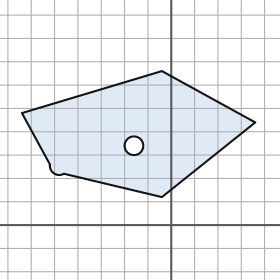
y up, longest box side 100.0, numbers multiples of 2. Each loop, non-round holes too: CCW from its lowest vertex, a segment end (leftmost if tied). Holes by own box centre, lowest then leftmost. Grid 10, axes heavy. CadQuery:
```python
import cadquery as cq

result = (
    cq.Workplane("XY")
    .moveTo(-4.0, 12.0)
    .lineTo(36.0, 44.0)
    .lineTo(-4.0, 66.0)
    .lineTo(-64.0, 48.0)
    .lineTo(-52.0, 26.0)
    .threePointArc((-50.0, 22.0), (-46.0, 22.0))
    .close()
    .moveTo(-16.0, 34.0)
    .circle(4.0)
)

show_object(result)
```